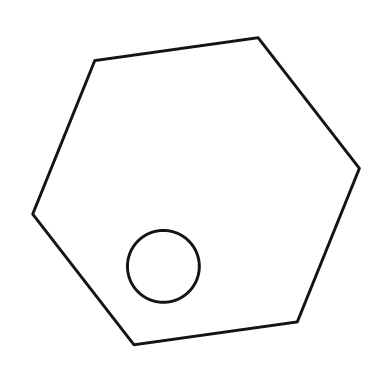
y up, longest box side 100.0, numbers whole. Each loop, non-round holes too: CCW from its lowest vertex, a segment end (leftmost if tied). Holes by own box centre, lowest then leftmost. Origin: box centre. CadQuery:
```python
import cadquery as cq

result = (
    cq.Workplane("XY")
    .moveTo(-19.0, -47.0)
    .lineTo(31.0, -40.0)
    .lineTo(50.0, 7.0)
    .lineTo(19.0, 47.0)
    .lineTo(-31.0, 40.0)
    .lineTo(-50.0, -7.0)
    .close()
    .moveTo(-10.0, -23.0)
    .circle(11.0)
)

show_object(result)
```